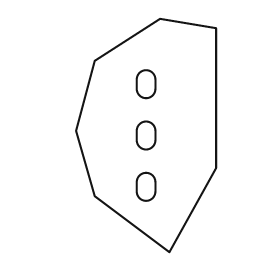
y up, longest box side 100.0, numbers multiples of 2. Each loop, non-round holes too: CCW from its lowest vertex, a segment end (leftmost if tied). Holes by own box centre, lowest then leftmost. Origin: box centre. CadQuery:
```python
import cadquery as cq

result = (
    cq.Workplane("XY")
    .moveTo(10.0, -50.0)
    .lineTo(30.0, -14.0)
    .lineTo(30.0, 46.0)
    .lineTo(6.0, 50.0)
    .lineTo(-22.0, 32.0)
    .lineTo(-30.0, 2.0)
    .lineTo(-22.0, -26.0)
    .close()
    .moveTo(-4.0, -24.0)
    .threePointArc((0.0, -28.0), (4.0, -24.0))
    .lineTo(4.0, -20.0)
    .threePointArc((0.0, -16.0), (-4.0, -20.0))
    .close()
    .moveTo(-4.0, -2.0)
    .threePointArc((0.0, -6.0), (4.0, -2.0))
    .lineTo(4.0, 2.0)
    .threePointArc((0.0, 6.0), (-4.0, 2.0))
    .close()
    .moveTo(-4.0, 20.0)
    .threePointArc((0.0, 16.0), (4.0, 20.0))
    .lineTo(4.0, 24.0)
    .threePointArc((0.0, 28.0), (-4.0, 24.0))
    .close()
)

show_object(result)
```